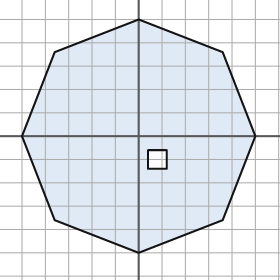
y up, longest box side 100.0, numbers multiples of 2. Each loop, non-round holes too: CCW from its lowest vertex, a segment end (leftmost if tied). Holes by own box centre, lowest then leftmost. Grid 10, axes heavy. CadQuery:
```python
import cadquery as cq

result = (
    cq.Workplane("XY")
    .moveTo(0.0, -50.0)
    .lineTo(36.0, -36.0)
    .lineTo(50.0, 0.0)
    .lineTo(36.0, 36.0)
    .lineTo(0.0, 50.0)
    .lineTo(-36.0, 36.0)
    .lineTo(-50.0, 0.0)
    .lineTo(-36.0, -36.0)
    .close()
    .moveTo(4.0, -14.0)
    .lineTo(12.0, -14.0)
    .lineTo(12.0, -6.0)
    .lineTo(4.0, -6.0)
    .close()
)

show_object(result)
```